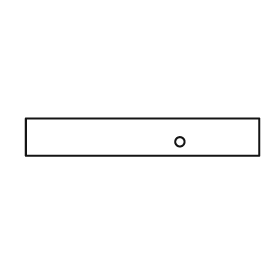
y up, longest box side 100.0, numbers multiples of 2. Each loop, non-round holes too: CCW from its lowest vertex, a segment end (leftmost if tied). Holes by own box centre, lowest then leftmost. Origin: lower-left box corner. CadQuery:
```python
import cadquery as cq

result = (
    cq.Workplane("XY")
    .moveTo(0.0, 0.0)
    .lineTo(100.0, 0.0)
    .lineTo(100.0, 16.0)
    .lineTo(0.0, 16.0)
    .close()
    .moveTo(66.0, 6.0)
    .circle(2.0)
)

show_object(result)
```